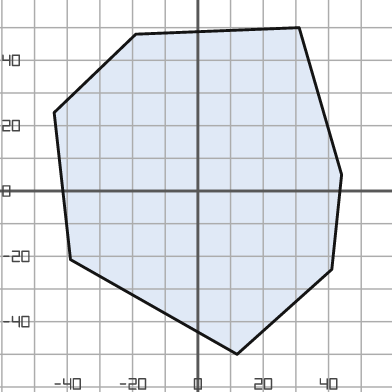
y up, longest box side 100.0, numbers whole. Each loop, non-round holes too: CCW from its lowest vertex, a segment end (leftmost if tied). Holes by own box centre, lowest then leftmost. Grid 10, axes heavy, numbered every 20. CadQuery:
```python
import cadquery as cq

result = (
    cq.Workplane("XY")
    .moveTo(12.0, -50.0)
    .lineTo(41.0, -24.0)
    .lineTo(44.0, 5.0)
    .lineTo(31.0, 50.0)
    .lineTo(-19.0, 48.0)
    .lineTo(-44.0, 24.0)
    .lineTo(-39.0, -21.0)
    .close()
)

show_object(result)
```